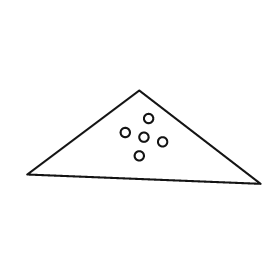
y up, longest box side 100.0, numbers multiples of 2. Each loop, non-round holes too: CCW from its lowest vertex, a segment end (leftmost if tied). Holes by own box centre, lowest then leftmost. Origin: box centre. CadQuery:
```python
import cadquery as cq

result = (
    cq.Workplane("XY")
    .moveTo(50.0, -20.0)
    .lineTo(-2.0, 20.0)
    .lineTo(-50.0, -16.0)
    .close()
    .moveTo(-2.0, -8.0)
    .circle(2.0)
    .moveTo(8.0, -2.0)
    .circle(2.0)
    .moveTo(0.0, 0.0)
    .circle(2.0)
    .moveTo(-8.0, 2.0)
    .circle(2.0)
    .moveTo(2.0, 8.0)
    .circle(2.0)
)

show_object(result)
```